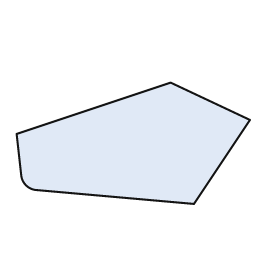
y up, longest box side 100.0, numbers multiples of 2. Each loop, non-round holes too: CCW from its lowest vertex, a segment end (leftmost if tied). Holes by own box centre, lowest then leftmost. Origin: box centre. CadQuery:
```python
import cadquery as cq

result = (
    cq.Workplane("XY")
    .moveTo(26.0, -26.0)
    .lineTo(50.0, 10.0)
    .lineTo(16.0, 26.0)
    .lineTo(-50.0, 4.0)
    .lineTo(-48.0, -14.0)
    .threePointArc((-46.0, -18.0), (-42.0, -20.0))
    .close()
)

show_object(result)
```